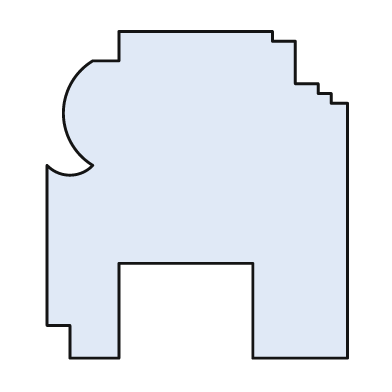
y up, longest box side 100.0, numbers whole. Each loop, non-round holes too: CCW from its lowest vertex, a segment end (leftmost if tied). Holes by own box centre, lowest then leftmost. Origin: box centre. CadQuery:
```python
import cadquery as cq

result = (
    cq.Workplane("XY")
    .moveTo(-39.0, -50.0)
    .lineTo(-24.0, -50.0)
    .lineTo(-24.0, -21.0)
    .lineTo(17.0, -21.0)
    .lineTo(17.0, -50.0)
    .lineTo(46.0, -50.0)
    .lineTo(46.0, 28.0)
    .lineTo(41.0, 28.0)
    .lineTo(41.0, 31.0)
    .lineTo(37.0, 31.0)
    .lineTo(37.0, 34.0)
    .lineTo(30.0, 34.0)
    .lineTo(30.0, 47.0)
    .lineTo(23.0, 47.0)
    .lineTo(23.0, 50.0)
    .lineTo(-24.0, 50.0)
    .lineTo(-24.0, 41.0)
    .lineTo(-32.0, 41.0)
    .threePointArc((-41.0, 25.0), (-32.0, 9.0))
    .threePointArc((-39.0, 6.0), (-46.0, 9.0))
    .lineTo(-46.0, -40.0)
    .lineTo(-39.0, -40.0)
    .close()
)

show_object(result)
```